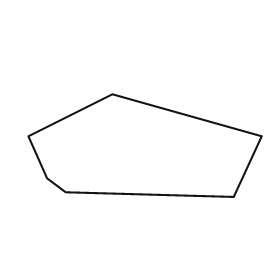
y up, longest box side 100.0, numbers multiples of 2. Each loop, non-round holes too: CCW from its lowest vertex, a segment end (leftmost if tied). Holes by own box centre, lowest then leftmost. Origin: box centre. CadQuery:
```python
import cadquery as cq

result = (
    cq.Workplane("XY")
    .moveTo(38.0, -22.0)
    .lineTo(50.0, 4.0)
    .lineTo(-14.0, 22.0)
    .lineTo(-50.0, 4.0)
    .lineTo(-42.0, -14.0)
    .lineTo(-34.0, -20.0)
    .close()
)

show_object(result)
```